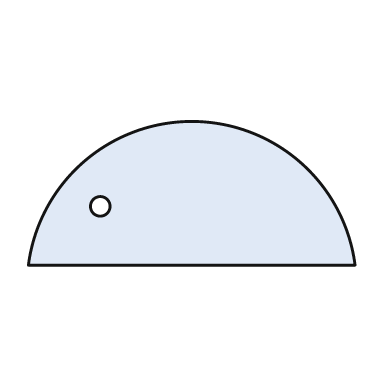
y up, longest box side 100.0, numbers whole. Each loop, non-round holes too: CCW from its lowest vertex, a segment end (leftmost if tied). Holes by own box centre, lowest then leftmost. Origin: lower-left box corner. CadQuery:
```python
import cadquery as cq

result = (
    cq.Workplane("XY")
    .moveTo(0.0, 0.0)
    .lineTo(100.0, 0.0)
    .threePointArc((50.0, 44.0), (0.0, 0.0))
    .close()
    .moveTo(22.0, 18.0)
    .circle(3.0)
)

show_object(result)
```